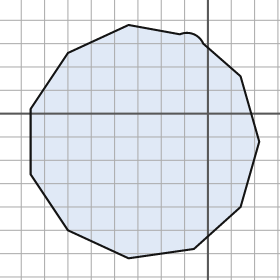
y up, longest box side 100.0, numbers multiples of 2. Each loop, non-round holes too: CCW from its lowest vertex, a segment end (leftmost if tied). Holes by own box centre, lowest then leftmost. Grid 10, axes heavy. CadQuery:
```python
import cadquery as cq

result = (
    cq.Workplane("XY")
    .moveTo(-34.0, -62.0)
    .lineTo(-6.0, -58.0)
    .lineTo(14.0, -40.0)
    .lineTo(22.0, -12.0)
    .lineTo(14.0, 16.0)
    .lineTo(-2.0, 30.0)
    .threePointArc((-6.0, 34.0), (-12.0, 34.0))
    .lineTo(-34.0, 38.0)
    .lineTo(-60.0, 26.0)
    .lineTo(-76.0, 2.0)
    .lineTo(-76.0, -26.0)
    .lineTo(-60.0, -50.0)
    .close()
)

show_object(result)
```